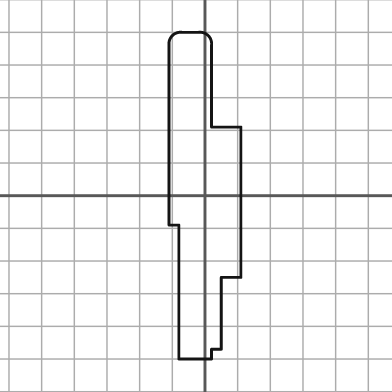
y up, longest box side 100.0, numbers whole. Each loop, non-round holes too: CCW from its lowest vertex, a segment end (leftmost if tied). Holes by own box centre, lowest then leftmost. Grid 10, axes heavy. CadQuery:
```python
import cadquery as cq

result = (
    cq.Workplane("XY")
    .moveTo(-8.0, -50.0)
    .lineTo(2.0, -50.0)
    .lineTo(2.0, -47.0)
    .lineTo(5.0, -47.0)
    .lineTo(5.0, -25.0)
    .lineTo(11.0, -25.0)
    .lineTo(11.0, 21.0)
    .lineTo(2.0, 21.0)
    .lineTo(2.0, 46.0)
    .threePointArc((1.0, 49.0), (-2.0, 50.0))
    .lineTo(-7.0, 50.0)
    .threePointArc((-10.0, 49.0), (-11.0, 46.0))
    .lineTo(-11.0, -9.0)
    .lineTo(-8.0, -9.0)
    .close()
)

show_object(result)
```